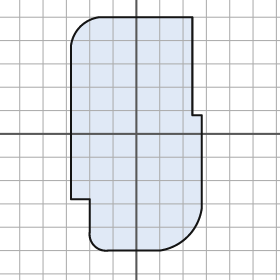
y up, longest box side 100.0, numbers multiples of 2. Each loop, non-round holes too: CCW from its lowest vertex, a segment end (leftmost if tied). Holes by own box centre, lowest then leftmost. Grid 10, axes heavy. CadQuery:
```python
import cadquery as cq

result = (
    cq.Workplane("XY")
    .moveTo(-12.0, -50.0)
    .lineTo(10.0, -50.0)
    .threePointArc((22.0, -44.0), (28.0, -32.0))
    .lineTo(28.0, 8.0)
    .lineTo(24.0, 8.0)
    .lineTo(24.0, 50.0)
    .lineTo(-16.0, 50.0)
    .threePointArc((-24.0, 46.0), (-28.0, 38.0))
    .lineTo(-28.0, -28.0)
    .lineTo(-20.0, -28.0)
    .lineTo(-20.0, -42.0)
    .threePointArc((-18.0, -48.0), (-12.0, -50.0))
    .close()
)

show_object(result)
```